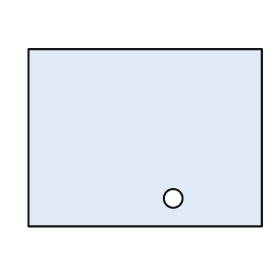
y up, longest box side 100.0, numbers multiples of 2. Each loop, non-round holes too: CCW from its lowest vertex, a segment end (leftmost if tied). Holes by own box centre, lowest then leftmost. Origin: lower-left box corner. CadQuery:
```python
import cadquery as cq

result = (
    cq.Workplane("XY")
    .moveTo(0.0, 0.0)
    .lineTo(100.0, 0.0)
    .lineTo(100.0, 76.0)
    .lineTo(0.0, 76.0)
    .close()
    .moveTo(62.0, 12.0)
    .circle(4.0)
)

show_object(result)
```